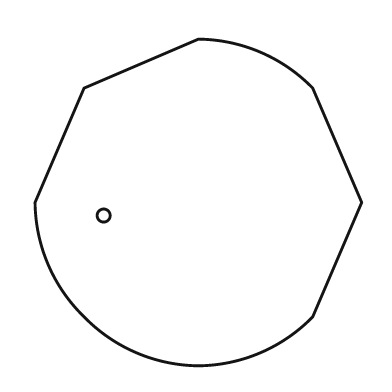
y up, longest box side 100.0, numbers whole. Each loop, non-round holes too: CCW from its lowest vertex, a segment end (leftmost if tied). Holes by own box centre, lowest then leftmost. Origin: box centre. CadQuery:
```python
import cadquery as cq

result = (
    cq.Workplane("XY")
    .moveTo(0.0, -50.0)
    .threePointArc((19.0, -46.0), (35.0, -35.0))
    .lineTo(50.0, 0.0)
    .lineTo(35.0, 35.0)
    .threePointArc((19.0, 46.0), (0.0, 50.0))
    .lineTo(-35.0, 35.0)
    .lineTo(-50.0, 0.0)
    .threePointArc((-46.0, -19.0), (-35.0, -35.0))
    .threePointArc((-19.0, -46.0), (0.0, -50.0))
    .close()
    .moveTo(-29.0, -4.0)
    .circle(2.0)
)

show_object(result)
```